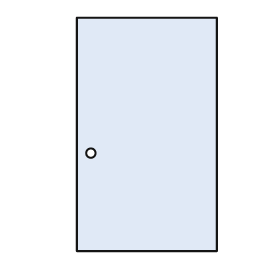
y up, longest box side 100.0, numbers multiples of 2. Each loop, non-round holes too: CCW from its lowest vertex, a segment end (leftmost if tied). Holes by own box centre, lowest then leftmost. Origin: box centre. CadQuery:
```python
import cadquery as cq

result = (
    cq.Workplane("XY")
    .moveTo(-30.0, -50.0)
    .lineTo(30.0, -50.0)
    .lineTo(30.0, 50.0)
    .lineTo(-30.0, 50.0)
    .close()
    .moveTo(-24.0, -8.0)
    .circle(2.0)
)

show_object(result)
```